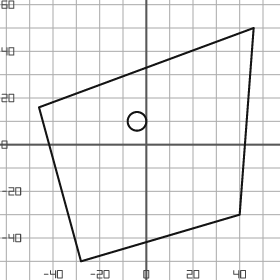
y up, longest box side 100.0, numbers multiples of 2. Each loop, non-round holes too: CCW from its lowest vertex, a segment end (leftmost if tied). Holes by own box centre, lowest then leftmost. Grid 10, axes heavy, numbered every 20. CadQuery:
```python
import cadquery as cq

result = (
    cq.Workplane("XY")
    .moveTo(-28.0, -50.0)
    .lineTo(40.0, -30.0)
    .lineTo(46.0, 50.0)
    .lineTo(-46.0, 16.0)
    .close()
    .moveTo(-4.0, 10.0)
    .circle(4.0)
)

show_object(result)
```